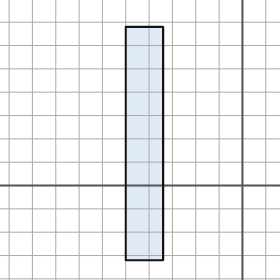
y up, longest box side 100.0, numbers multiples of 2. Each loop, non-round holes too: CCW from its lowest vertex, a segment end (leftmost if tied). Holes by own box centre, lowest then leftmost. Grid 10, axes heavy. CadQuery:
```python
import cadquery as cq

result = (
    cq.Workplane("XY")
    .moveTo(-50.0, -32.0)
    .lineTo(-34.0, -32.0)
    .lineTo(-34.0, 68.0)
    .lineTo(-50.0, 68.0)
    .close()
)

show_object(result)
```